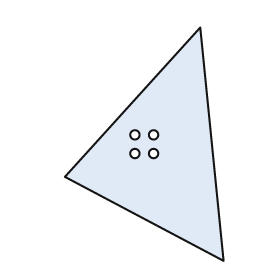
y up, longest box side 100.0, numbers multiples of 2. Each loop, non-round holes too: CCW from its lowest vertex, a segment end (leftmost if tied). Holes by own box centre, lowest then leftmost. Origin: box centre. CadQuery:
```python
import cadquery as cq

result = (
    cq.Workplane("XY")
    .moveTo(34.0, -50.0)
    .lineTo(24.0, 50.0)
    .lineTo(-34.0, -14.0)
    .close()
    .moveTo(-4.0, -4.0)
    .circle(2.0)
    .moveTo(4.0, -4.0)
    .circle(2.0)
    .moveTo(-4.0, 4.0)
    .circle(2.0)
    .moveTo(4.0, 4.0)
    .circle(2.0)
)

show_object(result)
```